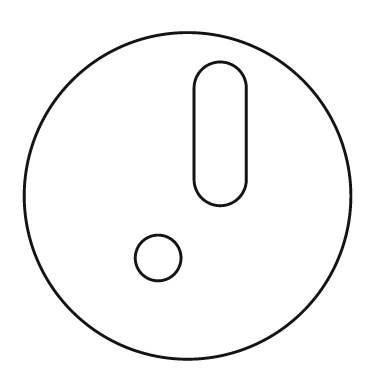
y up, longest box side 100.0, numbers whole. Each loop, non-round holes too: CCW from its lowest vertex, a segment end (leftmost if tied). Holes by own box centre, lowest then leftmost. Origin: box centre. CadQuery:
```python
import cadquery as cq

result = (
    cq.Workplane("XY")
    .moveTo(0.0, 0.0)
    .circle(50.0)
    .moveTo(-9.0, -19.0)
    .circle(7.0)
    .moveTo(2.0, 5.0)
    .threePointArc((10.0, -3.0), (18.0, 5.0))
    .lineTo(18.0, 33.0)
    .threePointArc((10.0, 41.0), (2.0, 33.0))
    .close()
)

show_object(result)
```